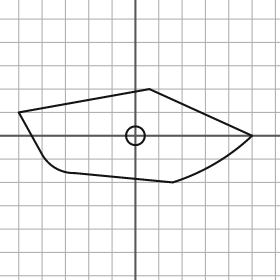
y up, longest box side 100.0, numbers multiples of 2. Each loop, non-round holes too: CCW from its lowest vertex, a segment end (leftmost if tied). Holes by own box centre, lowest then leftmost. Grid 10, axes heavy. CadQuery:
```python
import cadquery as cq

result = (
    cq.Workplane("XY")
    .moveTo(16.0, -20.0)
    .threePointArc((34.0, -12.0), (50.0, 0.0))
    .lineTo(6.0, 20.0)
    .lineTo(-50.0, 10.0)
    .lineTo(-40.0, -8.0)
    .threePointArc((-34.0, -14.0), (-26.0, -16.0))
    .close()
    .moveTo(0.0, 0.0)
    .circle(4.0)
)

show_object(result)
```